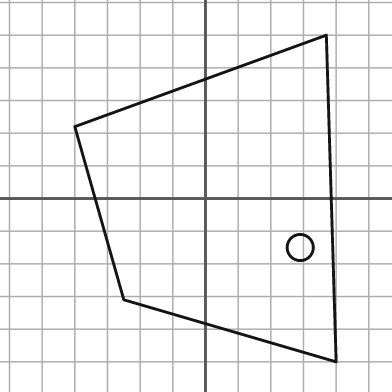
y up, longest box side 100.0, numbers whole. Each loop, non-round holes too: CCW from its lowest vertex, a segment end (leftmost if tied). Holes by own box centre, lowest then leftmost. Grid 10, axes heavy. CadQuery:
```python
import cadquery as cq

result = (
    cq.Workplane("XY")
    .moveTo(40.0, -50.0)
    .lineTo(37.0, 50.0)
    .lineTo(-40.0, 22.0)
    .lineTo(-25.0, -31.0)
    .close()
    .moveTo(29.0, -15.0)
    .circle(4.0)
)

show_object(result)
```